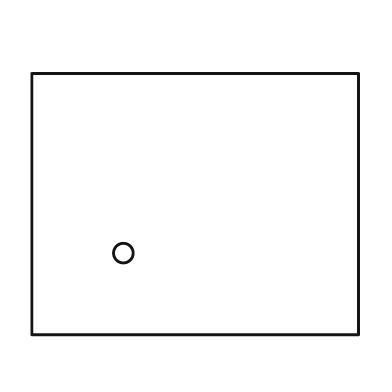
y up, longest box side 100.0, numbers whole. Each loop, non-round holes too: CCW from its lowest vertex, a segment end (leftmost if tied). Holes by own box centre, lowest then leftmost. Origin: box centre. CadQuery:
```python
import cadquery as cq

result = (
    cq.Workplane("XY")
    .moveTo(-50.0, -40.0)
    .lineTo(50.0, -40.0)
    .lineTo(50.0, 40.0)
    .lineTo(-50.0, 40.0)
    .close()
    .moveTo(-22.0, -15.0)
    .circle(3.0)
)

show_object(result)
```